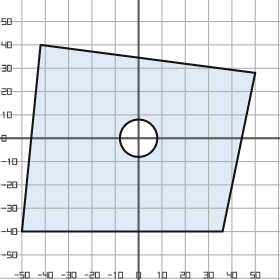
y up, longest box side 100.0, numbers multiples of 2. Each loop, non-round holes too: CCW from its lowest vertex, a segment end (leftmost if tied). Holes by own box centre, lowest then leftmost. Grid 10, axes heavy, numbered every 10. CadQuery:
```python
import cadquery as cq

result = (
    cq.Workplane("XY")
    .moveTo(-50.0, -40.0)
    .lineTo(36.0, -40.0)
    .lineTo(50.0, 28.0)
    .lineTo(-42.0, 40.0)
    .close()
    .moveTo(0.0, 0.0)
    .circle(8.0)
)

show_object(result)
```